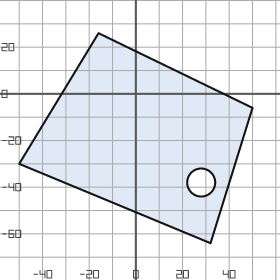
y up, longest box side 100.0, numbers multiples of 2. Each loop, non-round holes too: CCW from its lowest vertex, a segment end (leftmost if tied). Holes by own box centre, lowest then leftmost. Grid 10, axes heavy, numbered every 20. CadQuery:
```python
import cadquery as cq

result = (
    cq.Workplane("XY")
    .moveTo(32.0, -64.0)
    .lineTo(50.0, -6.0)
    .lineTo(-16.0, 26.0)
    .lineTo(-50.0, -30.0)
    .close()
    .moveTo(28.0, -38.0)
    .circle(6.0)
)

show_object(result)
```